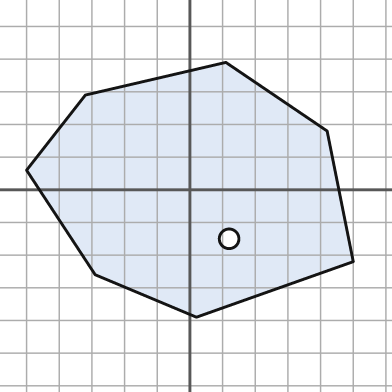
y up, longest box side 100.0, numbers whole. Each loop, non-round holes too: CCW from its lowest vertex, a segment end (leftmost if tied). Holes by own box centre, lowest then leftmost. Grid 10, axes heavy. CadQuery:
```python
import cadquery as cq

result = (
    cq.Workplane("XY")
    .moveTo(2.0, -39.0)
    .lineTo(50.0, -22.0)
    .lineTo(42.0, 18.0)
    .lineTo(11.0, 39.0)
    .lineTo(-32.0, 29.0)
    .lineTo(-50.0, 6.0)
    .lineTo(-29.0, -26.0)
    .close()
    .moveTo(12.0, -15.0)
    .circle(3.0)
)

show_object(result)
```